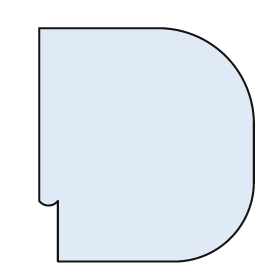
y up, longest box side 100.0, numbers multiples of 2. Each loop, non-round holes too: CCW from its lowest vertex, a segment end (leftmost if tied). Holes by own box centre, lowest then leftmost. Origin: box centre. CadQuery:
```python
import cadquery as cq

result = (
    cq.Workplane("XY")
    .moveTo(-38.0, -50.0)
    .lineTo(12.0, -50.0)
    .threePointArc((36.0, -40.0), (46.0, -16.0))
    .lineTo(46.0, 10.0)
    .threePointArc((34.0, 38.0), (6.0, 50.0))
    .lineTo(-46.0, 50.0)
    .lineTo(-46.0, -24.0)
    .threePointArc((-42.0, -26.0), (-38.0, -24.0))
    .close()
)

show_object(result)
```